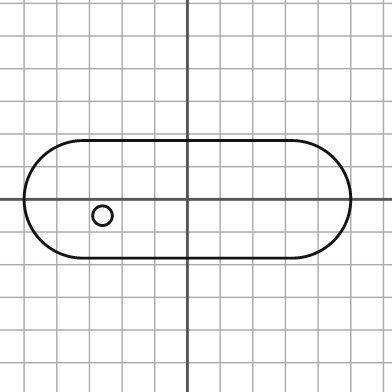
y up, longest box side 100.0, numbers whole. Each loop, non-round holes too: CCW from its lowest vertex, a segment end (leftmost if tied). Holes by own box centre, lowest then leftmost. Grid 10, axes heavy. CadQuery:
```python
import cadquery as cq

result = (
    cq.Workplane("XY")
    .moveTo(-32.0, -18.0)
    .lineTo(32.0, -18.0)
    .threePointArc((50.0, 0.0), (32.0, 18.0))
    .lineTo(-32.0, 18.0)
    .threePointArc((-50.0, 0.0), (-32.0, -18.0))
    .close()
    .moveTo(-26.0, -5.0)
    .circle(3.0)
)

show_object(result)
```